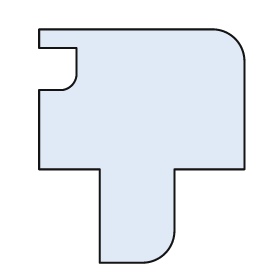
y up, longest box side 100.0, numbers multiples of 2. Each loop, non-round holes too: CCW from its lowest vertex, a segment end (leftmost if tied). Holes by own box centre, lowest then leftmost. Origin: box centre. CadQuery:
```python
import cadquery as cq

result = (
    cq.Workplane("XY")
    .moveTo(-18.0, -50.0)
    .lineTo(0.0, -50.0)
    .threePointArc((10.0, -46.0), (14.0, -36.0))
    .lineTo(14.0, -10.0)
    .lineTo(44.0, -10.0)
    .lineTo(44.0, 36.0)
    .threePointArc((40.0, 46.0), (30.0, 50.0))
    .lineTo(-44.0, 50.0)
    .lineTo(-44.0, 42.0)
    .lineTo(-28.0, 42.0)
    .lineTo(-28.0, 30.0)
    .threePointArc((-30.0, 26.0), (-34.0, 24.0))
    .lineTo(-44.0, 24.0)
    .lineTo(-44.0, -10.0)
    .lineTo(-18.0, -10.0)
    .close()
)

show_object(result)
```